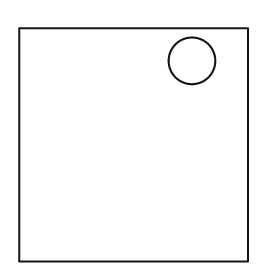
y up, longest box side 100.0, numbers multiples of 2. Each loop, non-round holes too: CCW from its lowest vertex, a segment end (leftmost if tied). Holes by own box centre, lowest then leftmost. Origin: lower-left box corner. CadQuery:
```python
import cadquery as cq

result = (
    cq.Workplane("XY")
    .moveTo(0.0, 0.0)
    .lineTo(98.0, 0.0)
    .lineTo(98.0, 100.0)
    .lineTo(0.0, 100.0)
    .close()
    .moveTo(74.0, 86.0)
    .circle(10.0)
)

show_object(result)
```